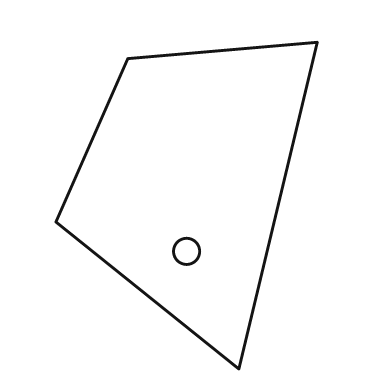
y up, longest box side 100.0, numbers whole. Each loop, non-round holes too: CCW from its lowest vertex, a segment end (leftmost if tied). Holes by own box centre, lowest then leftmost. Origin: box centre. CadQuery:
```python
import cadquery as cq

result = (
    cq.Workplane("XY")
    .moveTo(16.0, -50.0)
    .lineTo(40.0, 50.0)
    .lineTo(-18.0, 45.0)
    .lineTo(-40.0, -5.0)
    .close()
    .moveTo(0.0, -14.0)
    .circle(4.0)
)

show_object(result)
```